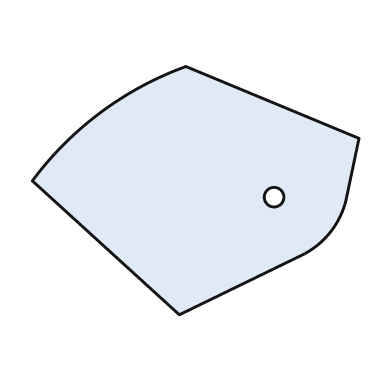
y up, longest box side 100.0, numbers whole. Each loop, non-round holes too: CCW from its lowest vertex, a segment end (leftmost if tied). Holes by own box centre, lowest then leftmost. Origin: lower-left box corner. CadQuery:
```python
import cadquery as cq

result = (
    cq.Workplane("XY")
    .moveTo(45.0, 0.0)
    .lineTo(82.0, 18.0)
    .threePointArc((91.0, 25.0), (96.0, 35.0))
    .lineTo(100.0, 54.0)
    .lineTo(47.0, 76.0)
    .threePointArc((21.0, 62.0), (0.0, 41.0))
    .close()
    .moveTo(74.0, 36.0)
    .circle(3.0)
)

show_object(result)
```